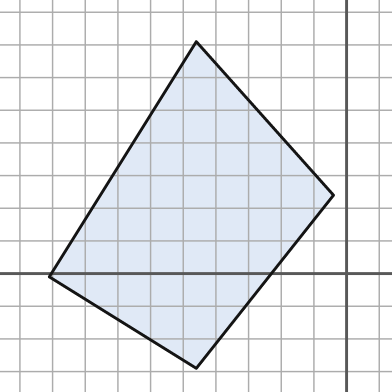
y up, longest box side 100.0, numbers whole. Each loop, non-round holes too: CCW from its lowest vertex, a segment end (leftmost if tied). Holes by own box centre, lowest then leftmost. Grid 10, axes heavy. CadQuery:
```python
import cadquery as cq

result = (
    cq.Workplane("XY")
    .moveTo(-46.0, -29.0)
    .lineTo(-4.0, 24.0)
    .lineTo(-46.0, 71.0)
    .lineTo(-91.0, -1.0)
    .close()
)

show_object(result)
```